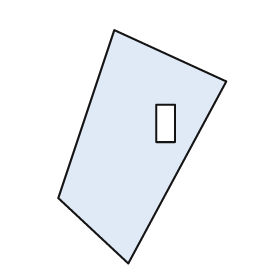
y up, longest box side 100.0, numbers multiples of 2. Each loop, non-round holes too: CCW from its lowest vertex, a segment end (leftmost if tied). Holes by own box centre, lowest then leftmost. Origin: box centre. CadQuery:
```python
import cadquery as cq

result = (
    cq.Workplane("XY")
    .moveTo(-6.0, -50.0)
    .lineTo(36.0, 28.0)
    .lineTo(-12.0, 50.0)
    .lineTo(-36.0, -22.0)
    .close()
    .moveTo(6.0, 2.0)
    .lineTo(14.0, 2.0)
    .lineTo(14.0, 18.0)
    .lineTo(6.0, 18.0)
    .close()
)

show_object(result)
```